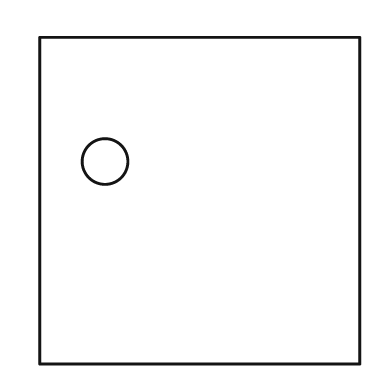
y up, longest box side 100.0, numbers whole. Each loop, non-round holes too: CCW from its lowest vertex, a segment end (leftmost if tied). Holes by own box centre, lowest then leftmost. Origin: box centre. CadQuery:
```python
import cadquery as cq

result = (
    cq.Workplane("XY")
    .moveTo(-49.0, -50.0)
    .lineTo(49.0, -50.0)
    .lineTo(49.0, 50.0)
    .lineTo(-49.0, 50.0)
    .close()
    .moveTo(-29.0, 12.0)
    .circle(7.0)
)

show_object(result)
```